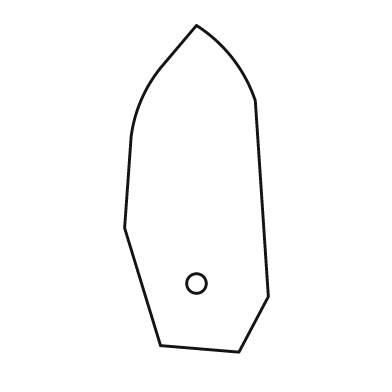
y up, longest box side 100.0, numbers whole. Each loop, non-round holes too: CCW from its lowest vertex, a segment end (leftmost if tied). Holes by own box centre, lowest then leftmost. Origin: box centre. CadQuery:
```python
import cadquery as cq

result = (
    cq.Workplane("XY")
    .moveTo(13.0, -50.0)
    .lineTo(22.0, -33.0)
    .lineTo(18.0, 27.0)
    .threePointArc((11.0, 40.0), (0.0, 50.0))
    .lineTo(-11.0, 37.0)
    .threePointArc((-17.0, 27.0), (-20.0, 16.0))
    .lineTo(-22.0, -12.0)
    .lineTo(-11.0, -48.0)
    .close()
    .moveTo(0.0, -29.0)
    .circle(3.0)
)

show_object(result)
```